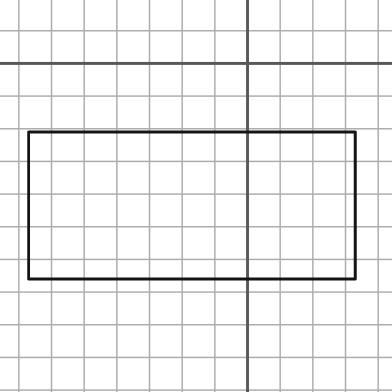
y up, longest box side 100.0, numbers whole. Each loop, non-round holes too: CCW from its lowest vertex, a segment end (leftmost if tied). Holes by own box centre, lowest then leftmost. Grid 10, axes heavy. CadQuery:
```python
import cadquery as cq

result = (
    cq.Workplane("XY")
    .moveTo(-67.0, -66.0)
    .lineTo(33.0, -66.0)
    .lineTo(33.0, -21.0)
    .lineTo(-67.0, -21.0)
    .close()
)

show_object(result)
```